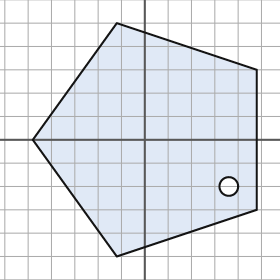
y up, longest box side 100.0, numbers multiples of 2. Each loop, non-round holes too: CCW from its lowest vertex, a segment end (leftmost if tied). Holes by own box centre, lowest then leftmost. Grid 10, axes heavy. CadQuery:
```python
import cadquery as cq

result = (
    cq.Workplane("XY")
    .moveTo(-12.0, -50.0)
    .lineTo(48.0, -30.0)
    .lineTo(48.0, 30.0)
    .lineTo(-12.0, 50.0)
    .lineTo(-48.0, 0.0)
    .close()
    .moveTo(36.0, -20.0)
    .circle(4.0)
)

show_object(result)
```